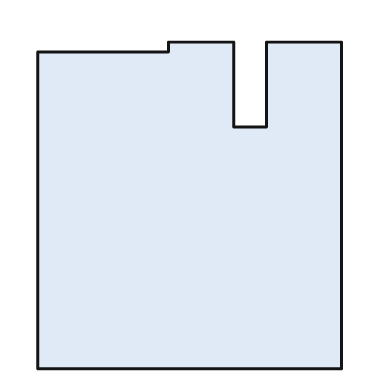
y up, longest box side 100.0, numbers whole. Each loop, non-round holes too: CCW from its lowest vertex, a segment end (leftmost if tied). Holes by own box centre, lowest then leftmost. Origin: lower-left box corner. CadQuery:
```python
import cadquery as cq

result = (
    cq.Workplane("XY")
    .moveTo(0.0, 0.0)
    .lineTo(93.0, 0.0)
    .lineTo(93.0, 100.0)
    .lineTo(70.0, 100.0)
    .lineTo(70.0, 74.0)
    .lineTo(60.0, 74.0)
    .lineTo(60.0, 100.0)
    .lineTo(40.0, 100.0)
    .lineTo(40.0, 97.0)
    .lineTo(0.0, 97.0)
    .close()
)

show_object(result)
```